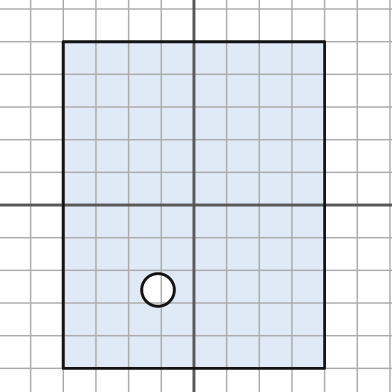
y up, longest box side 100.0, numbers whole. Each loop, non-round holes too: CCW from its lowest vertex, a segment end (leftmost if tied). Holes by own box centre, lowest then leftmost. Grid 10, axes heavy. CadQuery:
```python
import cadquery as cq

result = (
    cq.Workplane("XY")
    .moveTo(-40.0, -50.0)
    .lineTo(40.0, -50.0)
    .lineTo(40.0, 50.0)
    .lineTo(-40.0, 50.0)
    .close()
    .moveTo(-11.0, -26.0)
    .circle(5.0)
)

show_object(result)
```